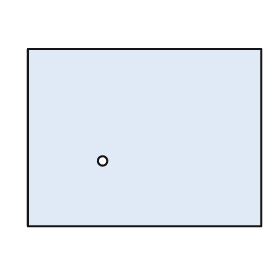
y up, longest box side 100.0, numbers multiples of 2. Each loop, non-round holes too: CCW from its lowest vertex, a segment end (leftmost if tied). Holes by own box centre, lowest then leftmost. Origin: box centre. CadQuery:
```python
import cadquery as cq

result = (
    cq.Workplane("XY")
    .moveTo(-50.0, -38.0)
    .lineTo(50.0, -38.0)
    .lineTo(50.0, 38.0)
    .lineTo(-50.0, 38.0)
    .close()
    .moveTo(-18.0, -10.0)
    .circle(2.0)
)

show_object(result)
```